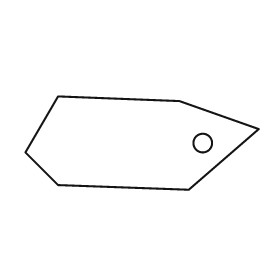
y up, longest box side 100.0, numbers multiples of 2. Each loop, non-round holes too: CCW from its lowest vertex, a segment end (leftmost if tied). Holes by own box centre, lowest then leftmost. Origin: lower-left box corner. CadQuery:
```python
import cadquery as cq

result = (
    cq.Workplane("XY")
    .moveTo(70.0, 0.0)
    .lineTo(100.0, 26.0)
    .lineTo(66.0, 38.0)
    .lineTo(14.0, 40.0)
    .lineTo(0.0, 16.0)
    .lineTo(14.0, 2.0)
    .close()
    .moveTo(76.0, 20.0)
    .circle(4.0)
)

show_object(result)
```